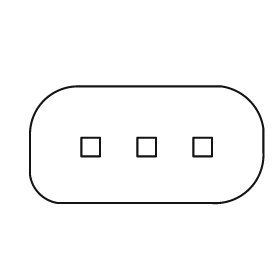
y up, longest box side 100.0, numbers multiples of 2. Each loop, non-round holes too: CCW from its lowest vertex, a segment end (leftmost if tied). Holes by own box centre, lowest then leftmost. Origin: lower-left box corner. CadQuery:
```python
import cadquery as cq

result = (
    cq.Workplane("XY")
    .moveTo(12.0, 0.0)
    .lineTo(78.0, 0.0)
    .threePointArc((94.0, 6.0), (100.0, 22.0))
    .lineTo(100.0, 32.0)
    .threePointArc((94.0, 44.0), (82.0, 50.0))
    .lineTo(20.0, 50.0)
    .threePointArc((6.0, 44.0), (0.0, 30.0))
    .lineTo(0.0, 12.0)
    .threePointArc((4.0, 4.0), (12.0, 0.0))
    .close()
    .moveTo(22.0, 20.0)
    .lineTo(30.0, 20.0)
    .lineTo(30.0, 28.0)
    .lineTo(22.0, 28.0)
    .close()
    .moveTo(46.0, 20.0)
    .lineTo(54.0, 20.0)
    .lineTo(54.0, 28.0)
    .lineTo(46.0, 28.0)
    .close()
    .moveTo(70.0, 20.0)
    .lineTo(78.0, 20.0)
    .lineTo(78.0, 28.0)
    .lineTo(70.0, 28.0)
    .close()
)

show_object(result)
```